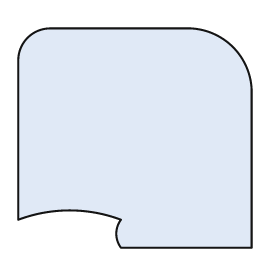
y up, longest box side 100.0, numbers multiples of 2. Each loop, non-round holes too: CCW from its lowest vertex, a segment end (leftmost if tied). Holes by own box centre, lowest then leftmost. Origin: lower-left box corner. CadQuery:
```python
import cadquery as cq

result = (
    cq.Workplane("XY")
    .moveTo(44.0, 0.0)
    .lineTo(100.0, 0.0)
    .lineTo(100.0, 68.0)
    .threePointArc((92.0, 86.0), (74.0, 94.0))
    .lineTo(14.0, 94.0)
    .threePointArc((4.0, 90.0), (0.0, 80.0))
    .lineTo(0.0, 12.0)
    .threePointArc((22.0, 16.0), (44.0, 12.0))
    .threePointArc((42.0, 6.0), (44.0, 0.0))
    .close()
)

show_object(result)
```